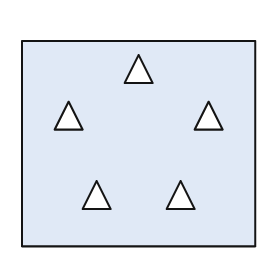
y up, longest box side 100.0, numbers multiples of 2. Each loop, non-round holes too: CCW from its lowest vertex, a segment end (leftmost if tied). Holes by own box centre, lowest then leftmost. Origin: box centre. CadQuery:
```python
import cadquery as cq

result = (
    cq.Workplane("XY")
    .moveTo(-50.0, -44.0)
    .lineTo(50.0, -44.0)
    .lineTo(50.0, 44.0)
    .lineTo(-50.0, 44.0)
    .close()
    .moveTo(-24.0, -28.0)
    .lineTo(-12.0, -28.0)
    .lineTo(-18.0, -16.0)
    .close()
    .moveTo(12.0, -28.0)
    .lineTo(24.0, -28.0)
    .lineTo(18.0, -16.0)
    .close()
    .moveTo(-36.0, 6.0)
    .lineTo(-24.0, 6.0)
    .lineTo(-30.0, 18.0)
    .close()
    .moveTo(24.0, 6.0)
    .lineTo(36.0, 6.0)
    .lineTo(30.0, 18.0)
    .close()
    .moveTo(-6.0, 26.0)
    .lineTo(6.0, 26.0)
    .lineTo(0.0, 38.0)
    .close()
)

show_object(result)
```